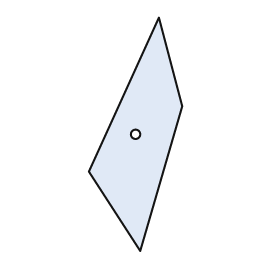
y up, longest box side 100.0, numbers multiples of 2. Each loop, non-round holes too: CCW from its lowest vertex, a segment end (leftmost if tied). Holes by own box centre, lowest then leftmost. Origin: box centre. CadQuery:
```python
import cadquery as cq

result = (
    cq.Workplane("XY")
    .moveTo(2.0, -50.0)
    .lineTo(20.0, 12.0)
    .lineTo(10.0, 50.0)
    .lineTo(-20.0, -16.0)
    .close()
    .moveTo(0.0, 0.0)
    .circle(2.0)
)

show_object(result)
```